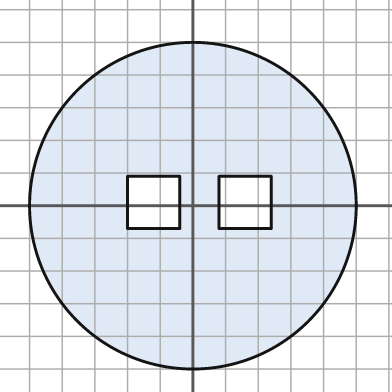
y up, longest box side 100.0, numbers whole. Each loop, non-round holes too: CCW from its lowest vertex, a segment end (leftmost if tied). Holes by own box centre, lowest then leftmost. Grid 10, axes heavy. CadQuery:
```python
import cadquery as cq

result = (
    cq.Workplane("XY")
    .moveTo(0.0, 0.0)
    .circle(50.0)
    .moveTo(-20.0, -7.0)
    .lineTo(-4.0, -7.0)
    .lineTo(-4.0, 9.0)
    .lineTo(-20.0, 9.0)
    .close()
    .moveTo(8.0, -7.0)
    .lineTo(24.0, -7.0)
    .lineTo(24.0, 9.0)
    .lineTo(8.0, 9.0)
    .close()
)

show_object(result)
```